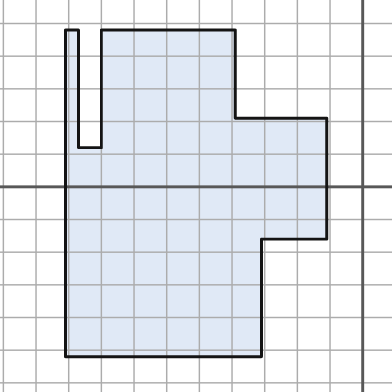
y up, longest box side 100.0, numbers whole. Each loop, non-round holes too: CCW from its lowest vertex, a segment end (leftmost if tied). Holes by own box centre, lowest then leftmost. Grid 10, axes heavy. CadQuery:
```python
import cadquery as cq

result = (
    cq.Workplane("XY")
    .moveTo(-91.0, -52.0)
    .lineTo(-31.0, -52.0)
    .lineTo(-31.0, -16.0)
    .lineTo(-11.0, -16.0)
    .lineTo(-11.0, 21.0)
    .lineTo(-39.0, 21.0)
    .lineTo(-39.0, 48.0)
    .lineTo(-80.0, 48.0)
    .lineTo(-80.0, 12.0)
    .lineTo(-87.0, 12.0)
    .lineTo(-87.0, 48.0)
    .lineTo(-91.0, 48.0)
    .close()
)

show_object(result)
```